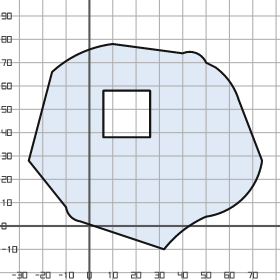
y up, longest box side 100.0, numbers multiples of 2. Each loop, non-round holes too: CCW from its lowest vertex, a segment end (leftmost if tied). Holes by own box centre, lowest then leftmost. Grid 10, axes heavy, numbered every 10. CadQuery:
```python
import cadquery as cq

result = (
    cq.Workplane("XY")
    .moveTo(32.0, -10.0)
    .threePointArc((40.0, -2.0), (50.0, 4.0))
    .threePointArc((66.0, 12.0), (74.0, 28.0))
    .lineTo(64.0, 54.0)
    .threePointArc((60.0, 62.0), (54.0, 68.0))
    .lineTo(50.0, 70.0)
    .threePointArc((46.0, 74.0), (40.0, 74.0))
    .lineTo(10.0, 78.0)
    .threePointArc((-4.0, 74.0), (-16.0, 66.0))
    .lineTo(-26.0, 28.0)
    .lineTo(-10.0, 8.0)
    .threePointArc((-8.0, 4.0), (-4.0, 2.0))
    .close()
    .moveTo(6.0, 38.0)
    .lineTo(26.0, 38.0)
    .lineTo(26.0, 58.0)
    .lineTo(6.0, 58.0)
    .close()
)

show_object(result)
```